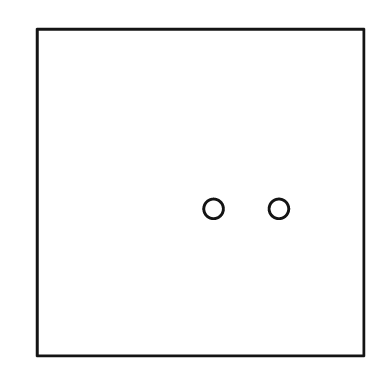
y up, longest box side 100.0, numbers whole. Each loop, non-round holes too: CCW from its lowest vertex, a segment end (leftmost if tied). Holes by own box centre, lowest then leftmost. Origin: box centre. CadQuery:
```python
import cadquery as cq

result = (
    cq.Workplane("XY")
    .moveTo(-50.0, -50.0)
    .lineTo(50.0, -50.0)
    .lineTo(50.0, 50.0)
    .lineTo(-50.0, 50.0)
    .close()
    .moveTo(4.0, -5.0)
    .circle(3.0)
    .moveTo(24.0, -5.0)
    .circle(3.0)
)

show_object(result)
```